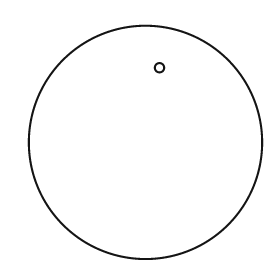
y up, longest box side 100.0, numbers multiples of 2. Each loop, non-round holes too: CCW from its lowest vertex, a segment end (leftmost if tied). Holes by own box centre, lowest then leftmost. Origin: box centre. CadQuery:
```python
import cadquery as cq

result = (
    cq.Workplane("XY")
    .moveTo(0.0, 0.0)
    .circle(50.0)
    .moveTo(6.0, 32.0)
    .circle(2.0)
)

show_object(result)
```